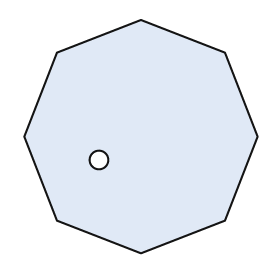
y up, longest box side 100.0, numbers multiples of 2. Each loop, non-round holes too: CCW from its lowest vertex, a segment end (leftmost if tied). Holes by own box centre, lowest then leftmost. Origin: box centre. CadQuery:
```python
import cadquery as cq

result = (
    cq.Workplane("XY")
    .moveTo(0.0, -50.0)
    .lineTo(36.0, -36.0)
    .lineTo(50.0, 0.0)
    .lineTo(36.0, 36.0)
    .lineTo(0.0, 50.0)
    .lineTo(-36.0, 36.0)
    .lineTo(-50.0, 0.0)
    .lineTo(-36.0, -36.0)
    .close()
    .moveTo(-18.0, -10.0)
    .circle(4.0)
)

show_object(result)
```